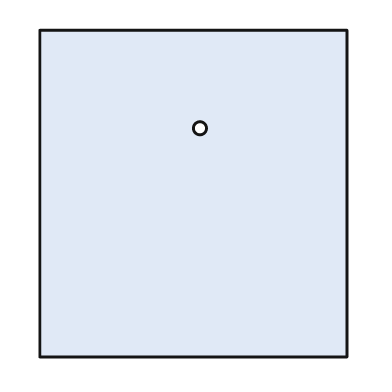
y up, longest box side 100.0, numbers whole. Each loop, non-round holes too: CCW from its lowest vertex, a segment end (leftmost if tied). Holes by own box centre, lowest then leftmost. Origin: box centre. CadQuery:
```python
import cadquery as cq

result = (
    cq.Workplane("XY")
    .moveTo(-47.0, -50.0)
    .lineTo(47.0, -50.0)
    .lineTo(47.0, 50.0)
    .lineTo(-47.0, 50.0)
    .close()
    .moveTo(2.0, 20.0)
    .circle(2.0)
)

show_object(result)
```